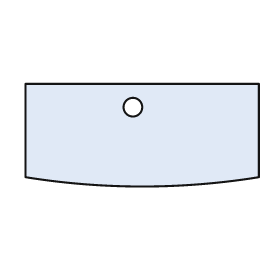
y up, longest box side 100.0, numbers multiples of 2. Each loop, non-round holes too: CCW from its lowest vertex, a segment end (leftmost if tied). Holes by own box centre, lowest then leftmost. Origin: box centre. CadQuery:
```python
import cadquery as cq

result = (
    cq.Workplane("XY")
    .moveTo(-50.0, -18.0)
    .threePointArc((0.0, -22.0), (50.0, -18.0))
    .lineTo(50.0, 22.0)
    .lineTo(-50.0, 22.0)
    .close()
    .moveTo(-4.0, 12.0)
    .circle(4.0)
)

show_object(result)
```